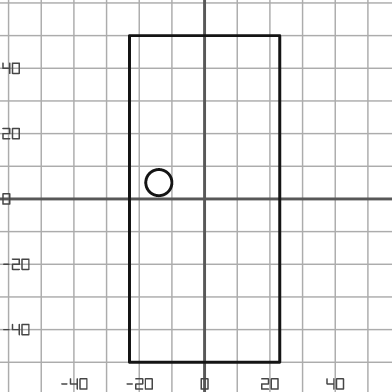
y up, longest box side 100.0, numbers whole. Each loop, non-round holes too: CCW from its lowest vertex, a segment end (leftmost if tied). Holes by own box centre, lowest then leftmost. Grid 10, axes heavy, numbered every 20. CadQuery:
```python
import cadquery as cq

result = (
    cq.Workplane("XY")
    .moveTo(-23.0, -50.0)
    .lineTo(23.0, -50.0)
    .lineTo(23.0, 50.0)
    .lineTo(-23.0, 50.0)
    .close()
    .moveTo(-14.0, 5.0)
    .circle(4.0)
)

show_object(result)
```